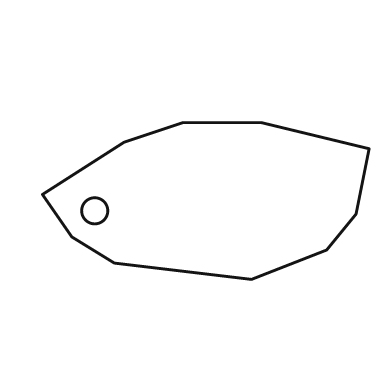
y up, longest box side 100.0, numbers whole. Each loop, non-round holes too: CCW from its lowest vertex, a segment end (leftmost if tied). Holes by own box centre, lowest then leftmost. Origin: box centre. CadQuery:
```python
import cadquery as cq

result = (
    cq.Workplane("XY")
    .moveTo(14.0, -24.0)
    .lineTo(37.0, -15.0)
    .lineTo(46.0, -4.0)
    .lineTo(50.0, 16.0)
    .lineTo(17.0, 24.0)
    .lineTo(-7.0, 24.0)
    .lineTo(-25.0, 18.0)
    .lineTo(-50.0, 2.0)
    .lineTo(-41.0, -11.0)
    .lineTo(-28.0, -19.0)
    .close()
    .moveTo(-34.0, -3.0)
    .circle(4.0)
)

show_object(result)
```